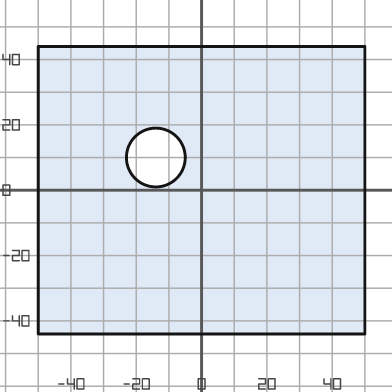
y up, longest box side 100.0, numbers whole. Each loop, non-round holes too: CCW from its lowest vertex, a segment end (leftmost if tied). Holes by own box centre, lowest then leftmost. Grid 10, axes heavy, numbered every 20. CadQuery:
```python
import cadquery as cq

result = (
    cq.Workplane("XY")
    .moveTo(-50.0, -44.0)
    .lineTo(50.0, -44.0)
    .lineTo(50.0, 44.0)
    .lineTo(-50.0, 44.0)
    .close()
    .moveTo(-14.0, 10.0)
    .circle(9.0)
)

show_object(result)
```